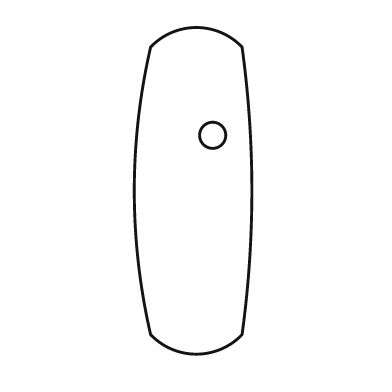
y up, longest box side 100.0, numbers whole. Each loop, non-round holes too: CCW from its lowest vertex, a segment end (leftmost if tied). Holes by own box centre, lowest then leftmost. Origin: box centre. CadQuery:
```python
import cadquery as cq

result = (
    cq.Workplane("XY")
    .moveTo(-13.0, -44.0)
    .threePointArc((1.0, -50.0), (15.0, -44.0))
    .threePointArc((18.0, 0.0), (15.0, 44.0))
    .threePointArc((1.0, 50.0), (-13.0, 44.0))
    .threePointArc((-18.0, 0.0), (-13.0, -44.0))
    .close()
    .moveTo(6.0, 17.0)
    .circle(4.0)
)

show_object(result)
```